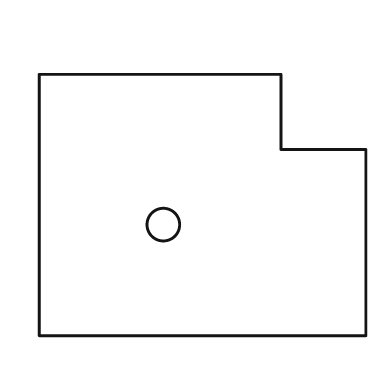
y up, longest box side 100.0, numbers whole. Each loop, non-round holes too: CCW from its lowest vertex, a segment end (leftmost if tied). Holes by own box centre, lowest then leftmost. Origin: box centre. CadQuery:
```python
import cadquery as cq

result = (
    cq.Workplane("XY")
    .moveTo(-50.0, -40.0)
    .lineTo(50.0, -40.0)
    .lineTo(50.0, 17.0)
    .lineTo(24.0, 17.0)
    .lineTo(24.0, 40.0)
    .lineTo(-50.0, 40.0)
    .close()
    .moveTo(-12.0, -6.0)
    .circle(5.0)
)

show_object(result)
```